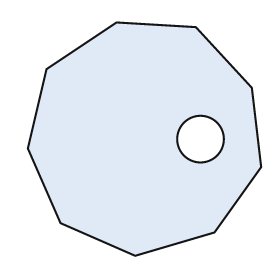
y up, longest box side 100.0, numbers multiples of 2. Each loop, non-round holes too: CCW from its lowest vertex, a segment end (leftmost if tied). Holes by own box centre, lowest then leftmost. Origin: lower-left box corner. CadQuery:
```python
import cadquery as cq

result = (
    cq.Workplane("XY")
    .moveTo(46.0, 0.0)
    .lineTo(80.0, 10.0)
    .lineTo(100.0, 38.0)
    .lineTo(96.0, 72.0)
    .lineTo(72.0, 98.0)
    .lineTo(38.0, 100.0)
    .lineTo(8.0, 80.0)
    .lineTo(0.0, 46.0)
    .lineTo(14.0, 14.0)
    .close()
    .moveTo(74.0, 50.0)
    .circle(10.0)
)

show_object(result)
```